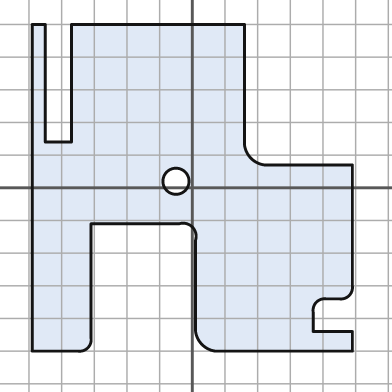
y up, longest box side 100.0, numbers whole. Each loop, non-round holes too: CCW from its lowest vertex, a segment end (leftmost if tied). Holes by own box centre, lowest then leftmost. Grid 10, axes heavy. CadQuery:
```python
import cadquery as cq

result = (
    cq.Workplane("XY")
    .moveTo(-49.0, -50.0)
    .lineTo(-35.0, -50.0)
    .threePointArc((-32.0, -49.0), (-31.0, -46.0))
    .lineTo(-31.0, -11.0)
    .lineTo(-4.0, -11.0)
    .threePointArc((0.0, -12.0), (1.0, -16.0))
    .lineTo(1.0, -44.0)
    .threePointArc((3.0, -48.0), (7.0, -50.0))
    .lineTo(49.0, -50.0)
    .lineTo(49.0, -44.0)
    .lineTo(37.0, -44.0)
    .lineTo(37.0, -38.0)
    .threePointArc((38.0, -35.0), (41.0, -34.0))
    .lineTo(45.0, -34.0)
    .threePointArc((48.0, -33.0), (49.0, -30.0))
    .lineTo(49.0, 7.0)
    .lineTo(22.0, 7.0)
    .threePointArc((18.0, 9.0), (16.0, 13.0))
    .lineTo(16.0, 50.0)
    .lineTo(-37.0, 50.0)
    .lineTo(-37.0, 14.0)
    .lineTo(-45.0, 14.0)
    .lineTo(-45.0, 50.0)
    .lineTo(-49.0, 50.0)
    .close()
    .moveTo(-5.0, 2.0)
    .circle(4.0)
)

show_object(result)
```